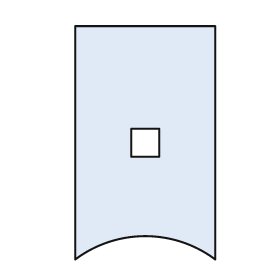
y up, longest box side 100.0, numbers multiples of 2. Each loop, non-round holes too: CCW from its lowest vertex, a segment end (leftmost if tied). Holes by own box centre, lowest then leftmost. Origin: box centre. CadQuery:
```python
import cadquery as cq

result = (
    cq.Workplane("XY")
    .moveTo(-30.0, -50.0)
    .threePointArc((0.0, -40.0), (30.0, -50.0))
    .lineTo(30.0, 50.0)
    .lineTo(-30.0, 50.0)
    .close()
    .moveTo(-6.0, -6.0)
    .lineTo(6.0, -6.0)
    .lineTo(6.0, 6.0)
    .lineTo(-6.0, 6.0)
    .close()
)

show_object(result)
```